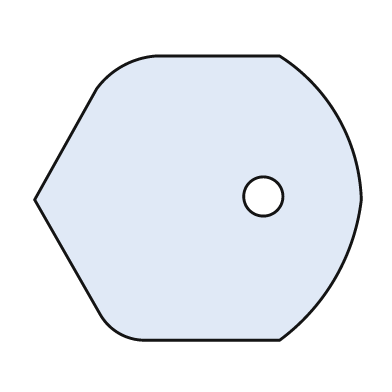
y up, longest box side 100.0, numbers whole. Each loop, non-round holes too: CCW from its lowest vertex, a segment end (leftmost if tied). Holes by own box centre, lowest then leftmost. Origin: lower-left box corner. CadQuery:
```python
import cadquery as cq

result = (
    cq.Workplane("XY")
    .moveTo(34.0, 0.0)
    .lineTo(75.0, 0.0)
    .threePointArc((92.0, 19.0), (100.0, 43.0))
    .threePointArc((93.0, 68.0), (75.0, 87.0))
    .lineTo(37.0, 87.0)
    .threePointArc((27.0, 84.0), (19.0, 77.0))
    .lineTo(0.0, 43.0)
    .lineTo(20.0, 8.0)
    .threePointArc((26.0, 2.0), (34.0, 0.0))
    .close()
    .moveTo(70.0, 44.0)
    .circle(6.0)
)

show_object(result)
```